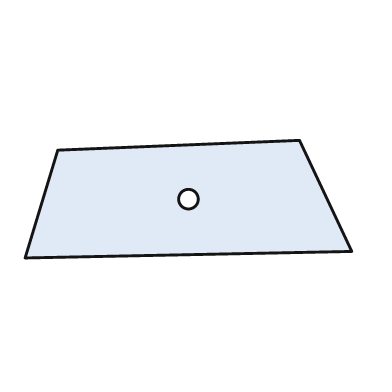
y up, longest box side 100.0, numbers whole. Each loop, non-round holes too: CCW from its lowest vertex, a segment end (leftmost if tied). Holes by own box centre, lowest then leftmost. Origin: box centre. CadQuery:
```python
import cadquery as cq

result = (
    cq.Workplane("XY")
    .moveTo(-50.0, -18.0)
    .lineTo(50.0, -16.0)
    .lineTo(34.0, 18.0)
    .lineTo(-40.0, 15.0)
    .close()
    .moveTo(0.0, 0.0)
    .circle(3.0)
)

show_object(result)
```